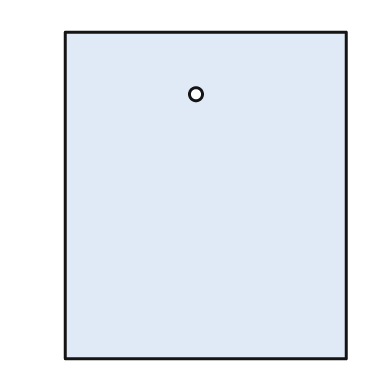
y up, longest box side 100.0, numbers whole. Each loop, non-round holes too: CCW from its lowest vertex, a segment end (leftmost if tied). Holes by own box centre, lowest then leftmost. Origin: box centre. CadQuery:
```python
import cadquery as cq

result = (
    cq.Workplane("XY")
    .moveTo(-43.0, -50.0)
    .lineTo(43.0, -50.0)
    .lineTo(43.0, 50.0)
    .lineTo(-43.0, 50.0)
    .close()
    .moveTo(-3.0, 31.0)
    .circle(2.0)
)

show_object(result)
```